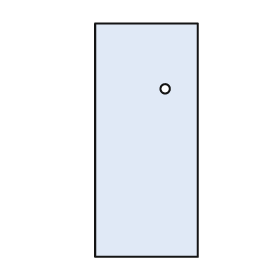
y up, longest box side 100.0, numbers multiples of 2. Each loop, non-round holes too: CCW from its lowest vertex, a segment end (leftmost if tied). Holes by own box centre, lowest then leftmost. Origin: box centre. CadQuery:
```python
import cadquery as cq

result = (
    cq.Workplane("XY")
    .moveTo(-22.0, -50.0)
    .lineTo(22.0, -50.0)
    .lineTo(22.0, 50.0)
    .lineTo(-22.0, 50.0)
    .close()
    .moveTo(8.0, 22.0)
    .circle(2.0)
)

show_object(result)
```